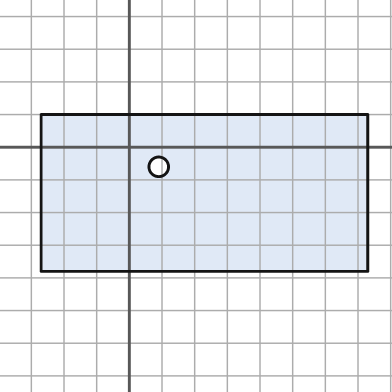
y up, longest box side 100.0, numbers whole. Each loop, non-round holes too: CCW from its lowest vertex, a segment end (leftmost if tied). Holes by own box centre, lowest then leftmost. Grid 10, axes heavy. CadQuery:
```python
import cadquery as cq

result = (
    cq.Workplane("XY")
    .moveTo(-27.0, -38.0)
    .lineTo(73.0, -38.0)
    .lineTo(73.0, 10.0)
    .lineTo(-27.0, 10.0)
    .close()
    .moveTo(9.0, -6.0)
    .circle(3.0)
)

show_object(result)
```